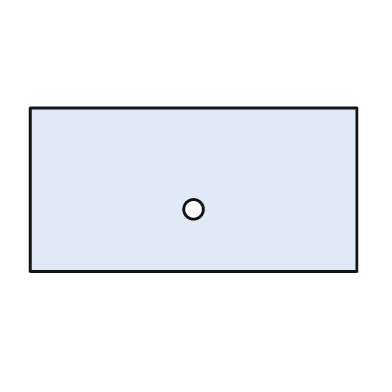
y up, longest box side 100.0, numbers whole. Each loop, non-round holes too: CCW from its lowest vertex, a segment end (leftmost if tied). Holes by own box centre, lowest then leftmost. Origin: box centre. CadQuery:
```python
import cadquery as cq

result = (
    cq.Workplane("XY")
    .moveTo(-50.0, -25.0)
    .lineTo(50.0, -25.0)
    .lineTo(50.0, 25.0)
    .lineTo(-50.0, 25.0)
    .close()
    .moveTo(0.0, -6.0)
    .circle(3.0)
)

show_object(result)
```